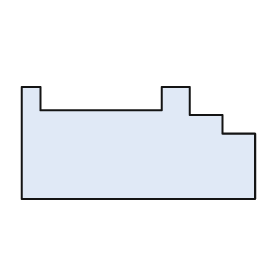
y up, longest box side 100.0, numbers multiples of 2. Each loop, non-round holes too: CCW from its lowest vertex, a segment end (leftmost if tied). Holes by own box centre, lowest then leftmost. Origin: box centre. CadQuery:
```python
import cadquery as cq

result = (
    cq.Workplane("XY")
    .moveTo(-50.0, -24.0)
    .lineTo(50.0, -24.0)
    .lineTo(50.0, 4.0)
    .lineTo(36.0, 4.0)
    .lineTo(36.0, 12.0)
    .lineTo(22.0, 12.0)
    .lineTo(22.0, 24.0)
    .lineTo(10.0, 24.0)
    .lineTo(10.0, 14.0)
    .lineTo(-42.0, 14.0)
    .lineTo(-42.0, 24.0)
    .lineTo(-50.0, 24.0)
    .close()
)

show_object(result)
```